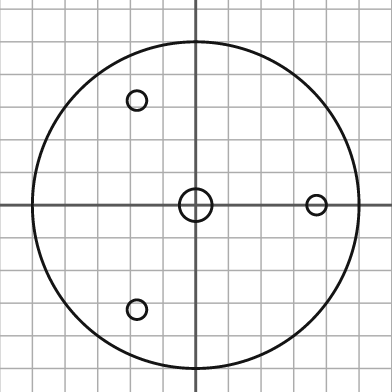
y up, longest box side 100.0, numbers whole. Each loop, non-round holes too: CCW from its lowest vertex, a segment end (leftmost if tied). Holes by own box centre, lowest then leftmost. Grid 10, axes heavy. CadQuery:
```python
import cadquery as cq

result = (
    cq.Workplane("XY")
    .moveTo(0.0, 0.0)
    .circle(50.0)
    .moveTo(-18.0, -32.0)
    .circle(3.0)
    .moveTo(0.0, 0.0)
    .circle(5.0)
    .moveTo(37.0, 0.0)
    .circle(3.0)
    .moveTo(-18.0, 32.0)
    .circle(3.0)
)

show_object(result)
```